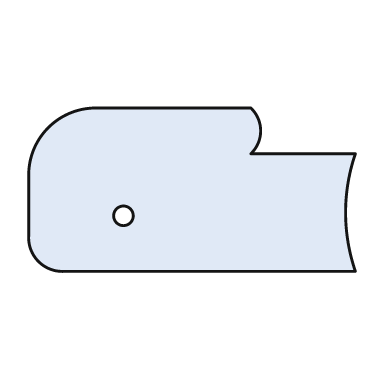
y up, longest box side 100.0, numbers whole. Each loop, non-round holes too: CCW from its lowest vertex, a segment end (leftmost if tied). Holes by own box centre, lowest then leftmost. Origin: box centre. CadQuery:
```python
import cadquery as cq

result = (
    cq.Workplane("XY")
    .moveTo(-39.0, -25.0)
    .lineTo(50.0, -25.0)
    .threePointArc((47.0, -7.0), (50.0, 11.0))
    .lineTo(18.0, 11.0)
    .threePointArc((21.0, 18.0), (18.0, 25.0))
    .lineTo(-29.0, 25.0)
    .threePointArc((-44.0, 19.0), (-50.0, 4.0))
    .lineTo(-50.0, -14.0)
    .threePointArc((-47.0, -22.0), (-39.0, -25.0))
    .close()
    .moveTo(-21.0, -8.0)
    .circle(3.0)
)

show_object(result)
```